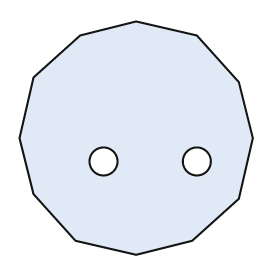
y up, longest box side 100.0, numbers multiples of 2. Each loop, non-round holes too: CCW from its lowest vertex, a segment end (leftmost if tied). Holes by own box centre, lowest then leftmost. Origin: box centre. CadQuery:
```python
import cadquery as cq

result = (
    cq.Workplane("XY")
    .moveTo(0.0, -50.0)
    .lineTo(24.0, -44.0)
    .lineTo(44.0, -26.0)
    .lineTo(50.0, 0.0)
    .lineTo(44.0, 24.0)
    .lineTo(26.0, 44.0)
    .lineTo(0.0, 50.0)
    .lineTo(-24.0, 44.0)
    .lineTo(-44.0, 26.0)
    .lineTo(-50.0, 0.0)
    .lineTo(-44.0, -24.0)
    .lineTo(-26.0, -44.0)
    .close()
    .moveTo(-14.0, -10.0)
    .circle(6.0)
    .moveTo(26.0, -10.0)
    .circle(6.0)
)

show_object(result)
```